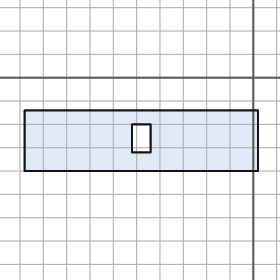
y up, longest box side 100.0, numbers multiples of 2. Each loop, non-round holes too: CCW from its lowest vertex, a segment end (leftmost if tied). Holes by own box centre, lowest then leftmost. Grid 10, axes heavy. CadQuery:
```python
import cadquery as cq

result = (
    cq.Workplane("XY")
    .moveTo(-98.0, -40.0)
    .lineTo(2.0, -40.0)
    .lineTo(2.0, -14.0)
    .lineTo(-98.0, -14.0)
    .close()
    .moveTo(-52.0, -32.0)
    .lineTo(-44.0, -32.0)
    .lineTo(-44.0, -20.0)
    .lineTo(-52.0, -20.0)
    .close()
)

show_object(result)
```